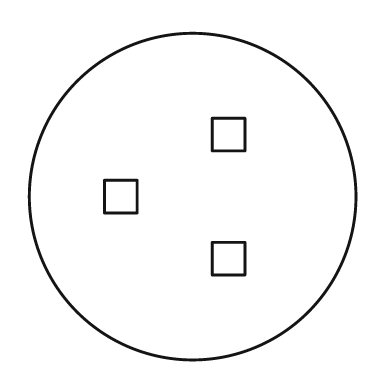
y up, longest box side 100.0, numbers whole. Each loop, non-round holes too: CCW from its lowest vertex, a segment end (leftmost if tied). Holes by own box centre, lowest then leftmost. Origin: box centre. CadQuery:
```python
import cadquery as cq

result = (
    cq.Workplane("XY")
    .moveTo(0.0, 0.0)
    .circle(50.0)
    .moveTo(6.0, -24.0)
    .lineTo(16.0, -24.0)
    .lineTo(16.0, -14.0)
    .lineTo(6.0, -14.0)
    .close()
    .moveTo(-27.0, -5.0)
    .lineTo(-17.0, -5.0)
    .lineTo(-17.0, 5.0)
    .lineTo(-27.0, 5.0)
    .close()
    .moveTo(6.0, 14.0)
    .lineTo(16.0, 14.0)
    .lineTo(16.0, 24.0)
    .lineTo(6.0, 24.0)
    .close()
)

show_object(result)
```